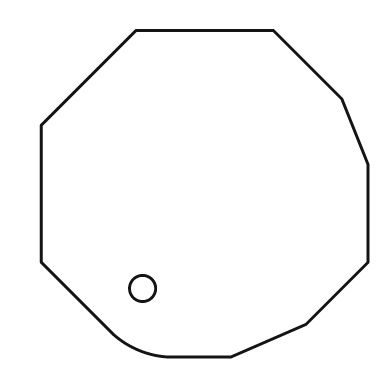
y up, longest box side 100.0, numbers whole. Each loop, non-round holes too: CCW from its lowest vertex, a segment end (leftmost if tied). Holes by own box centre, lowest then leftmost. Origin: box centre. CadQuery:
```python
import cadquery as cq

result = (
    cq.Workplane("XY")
    .moveTo(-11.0, -50.0)
    .lineTo(8.0, -50.0)
    .lineTo(31.0, -40.0)
    .lineTo(50.0, -21.0)
    .lineTo(50.0, 9.0)
    .lineTo(42.0, 29.0)
    .lineTo(21.0, 50.0)
    .lineTo(-21.0, 50.0)
    .lineTo(-50.0, 21.0)
    .lineTo(-50.0, -21.0)
    .lineTo(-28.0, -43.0)
    .threePointArc((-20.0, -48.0), (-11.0, -50.0))
    .close()
    .moveTo(-19.0, -29.0)
    .circle(4.0)
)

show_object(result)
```